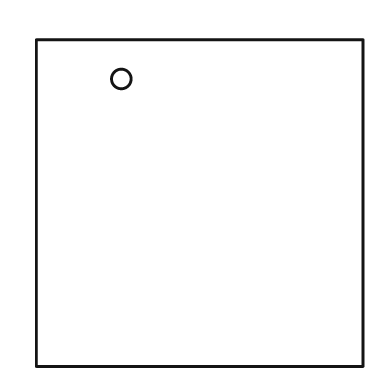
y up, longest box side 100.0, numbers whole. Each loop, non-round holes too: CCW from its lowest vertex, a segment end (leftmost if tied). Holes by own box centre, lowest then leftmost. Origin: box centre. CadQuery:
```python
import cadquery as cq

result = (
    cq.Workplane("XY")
    .moveTo(-50.0, -50.0)
    .lineTo(50.0, -50.0)
    .lineTo(50.0, 50.0)
    .lineTo(-50.0, 50.0)
    .close()
    .moveTo(-24.0, 38.0)
    .circle(3.0)
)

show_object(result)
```